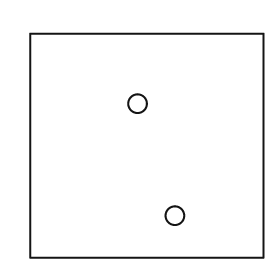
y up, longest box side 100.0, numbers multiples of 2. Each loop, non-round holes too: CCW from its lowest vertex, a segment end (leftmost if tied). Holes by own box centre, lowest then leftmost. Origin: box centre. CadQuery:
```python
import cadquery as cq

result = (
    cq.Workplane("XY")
    .moveTo(-50.0, -48.0)
    .lineTo(50.0, -48.0)
    .lineTo(50.0, 48.0)
    .lineTo(-50.0, 48.0)
    .close()
    .moveTo(12.0, -30.0)
    .circle(4.0)
    .moveTo(-4.0, 18.0)
    .circle(4.0)
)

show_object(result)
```